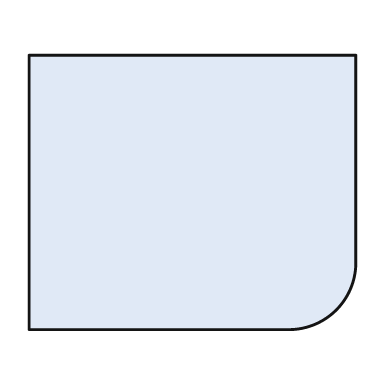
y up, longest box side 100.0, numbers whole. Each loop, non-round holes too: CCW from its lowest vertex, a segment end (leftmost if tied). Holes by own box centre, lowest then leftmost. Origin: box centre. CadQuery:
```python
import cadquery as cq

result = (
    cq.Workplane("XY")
    .moveTo(-50.0, -42.0)
    .lineTo(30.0, -42.0)
    .threePointArc((44.0, -36.0), (50.0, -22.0))
    .lineTo(50.0, 42.0)
    .lineTo(-50.0, 42.0)
    .close()
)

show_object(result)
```